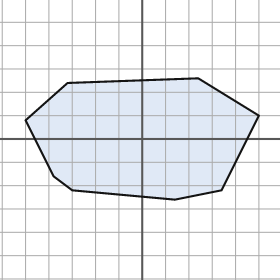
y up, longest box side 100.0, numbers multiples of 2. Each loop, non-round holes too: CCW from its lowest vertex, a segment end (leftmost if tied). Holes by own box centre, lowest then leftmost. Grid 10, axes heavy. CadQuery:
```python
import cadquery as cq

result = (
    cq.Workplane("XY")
    .moveTo(14.0, -26.0)
    .lineTo(34.0, -22.0)
    .lineTo(50.0, 10.0)
    .lineTo(24.0, 26.0)
    .lineTo(-32.0, 24.0)
    .lineTo(-50.0, 8.0)
    .lineTo(-38.0, -16.0)
    .lineTo(-30.0, -22.0)
    .close()
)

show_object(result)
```